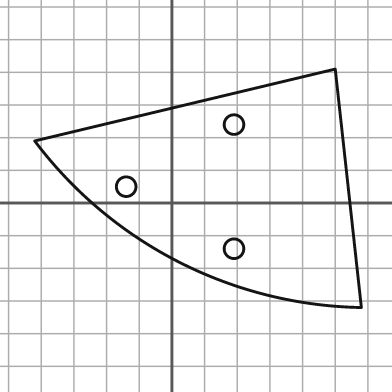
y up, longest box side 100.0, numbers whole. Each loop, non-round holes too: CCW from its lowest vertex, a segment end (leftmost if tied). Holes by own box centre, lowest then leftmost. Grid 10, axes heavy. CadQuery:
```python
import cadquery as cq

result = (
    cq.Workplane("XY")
    .moveTo(58.0, -32.0)
    .lineTo(50.0, 41.0)
    .lineTo(-42.0, 19.0)
    .threePointArc((2.0, -18.0), (58.0, -32.0))
    .close()
    .moveTo(19.0, -14.0)
    .circle(3.0)
    .moveTo(-14.0, 5.0)
    .circle(3.0)
    .moveTo(19.0, 24.0)
    .circle(3.0)
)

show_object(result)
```